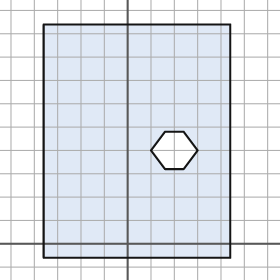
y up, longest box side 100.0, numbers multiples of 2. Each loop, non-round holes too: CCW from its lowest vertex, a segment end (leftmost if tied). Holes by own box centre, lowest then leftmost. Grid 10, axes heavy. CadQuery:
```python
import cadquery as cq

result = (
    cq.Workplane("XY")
    .moveTo(-36.0, -6.0)
    .lineTo(44.0, -6.0)
    .lineTo(44.0, 94.0)
    .lineTo(-36.0, 94.0)
    .close()
    .moveTo(16.0, 32.0)
    .lineTo(24.0, 32.0)
    .lineTo(30.0, 40.0)
    .lineTo(24.0, 48.0)
    .lineTo(16.0, 48.0)
    .lineTo(10.0, 40.0)
    .close()
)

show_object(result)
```